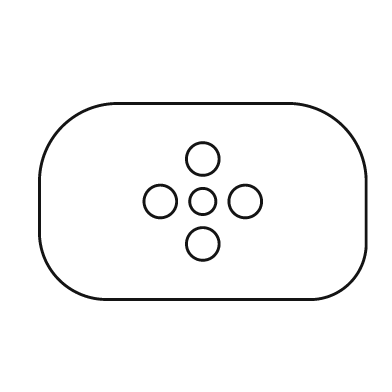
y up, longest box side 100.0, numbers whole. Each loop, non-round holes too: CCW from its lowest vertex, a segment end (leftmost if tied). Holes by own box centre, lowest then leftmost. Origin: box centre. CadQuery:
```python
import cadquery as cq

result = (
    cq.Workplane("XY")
    .moveTo(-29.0, -30.0)
    .lineTo(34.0, -30.0)
    .threePointArc((45.0, -25.0), (50.0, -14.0))
    .lineTo(50.0, 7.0)
    .threePointArc((43.0, 23.0), (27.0, 30.0))
    .lineTo(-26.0, 30.0)
    .threePointArc((-43.0, 23.0), (-50.0, 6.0))
    .lineTo(-50.0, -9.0)
    .threePointArc((-44.0, -24.0), (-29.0, -30.0))
    .close()
    .moveTo(0.0, -13.0)
    .circle(5.0)
    .moveTo(-13.0, 0.0)
    .circle(5.0)
    .moveTo(0.0, 0.0)
    .circle(4.0)
    .moveTo(13.0, 0.0)
    .circle(5.0)
    .moveTo(0.0, 13.0)
    .circle(5.0)
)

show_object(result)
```